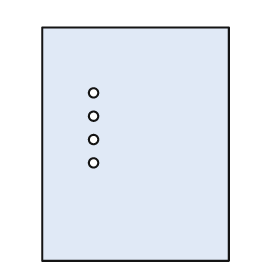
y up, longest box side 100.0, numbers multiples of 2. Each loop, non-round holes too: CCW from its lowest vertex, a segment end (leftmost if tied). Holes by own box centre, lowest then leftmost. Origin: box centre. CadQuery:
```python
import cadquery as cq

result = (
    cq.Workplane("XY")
    .moveTo(-40.0, -50.0)
    .lineTo(40.0, -50.0)
    .lineTo(40.0, 50.0)
    .lineTo(-40.0, 50.0)
    .close()
    .moveTo(-18.0, -8.0)
    .circle(2.0)
    .moveTo(-18.0, 2.0)
    .circle(2.0)
    .moveTo(-18.0, 12.0)
    .circle(2.0)
    .moveTo(-18.0, 22.0)
    .circle(2.0)
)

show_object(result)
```